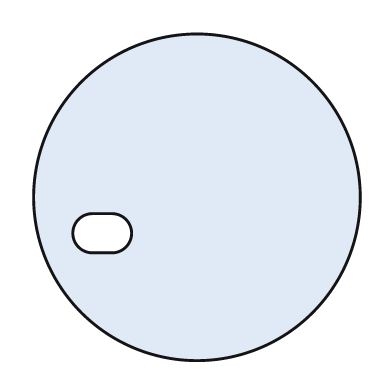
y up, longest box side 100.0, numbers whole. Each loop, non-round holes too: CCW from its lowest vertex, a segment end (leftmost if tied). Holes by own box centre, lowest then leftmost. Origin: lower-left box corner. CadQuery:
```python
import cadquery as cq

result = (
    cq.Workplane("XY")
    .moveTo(50.0, 50.0)
    .circle(50.0)
    .moveTo(18.0, 33.0)
    .lineTo(24.0, 33.0)
    .threePointArc((30.0, 39.0), (24.0, 45.0))
    .lineTo(18.0, 45.0)
    .threePointArc((12.0, 39.0), (18.0, 33.0))
    .close()
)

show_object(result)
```